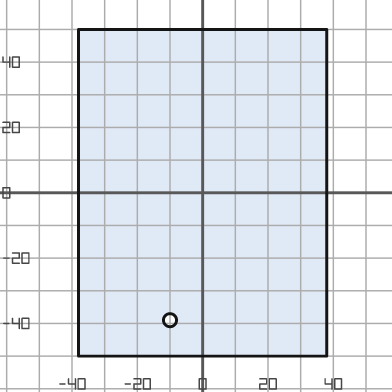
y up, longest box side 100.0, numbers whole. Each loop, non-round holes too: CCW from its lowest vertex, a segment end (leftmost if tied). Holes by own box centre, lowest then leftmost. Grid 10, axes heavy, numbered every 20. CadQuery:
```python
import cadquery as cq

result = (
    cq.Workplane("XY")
    .moveTo(-38.0, -50.0)
    .lineTo(38.0, -50.0)
    .lineTo(38.0, 50.0)
    .lineTo(-38.0, 50.0)
    .close()
    .moveTo(-10.0, -39.0)
    .circle(2.0)
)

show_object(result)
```